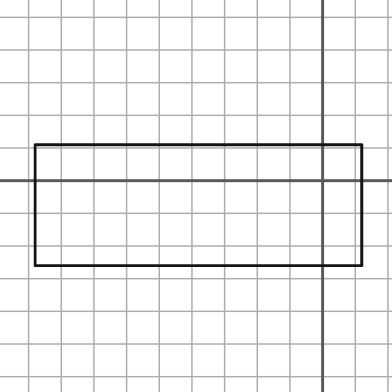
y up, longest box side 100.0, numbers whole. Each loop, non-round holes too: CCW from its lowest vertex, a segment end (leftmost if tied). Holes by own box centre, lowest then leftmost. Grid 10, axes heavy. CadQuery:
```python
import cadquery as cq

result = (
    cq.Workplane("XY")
    .moveTo(-88.0, -26.0)
    .lineTo(12.0, -26.0)
    .lineTo(12.0, 11.0)
    .lineTo(-88.0, 11.0)
    .close()
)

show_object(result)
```